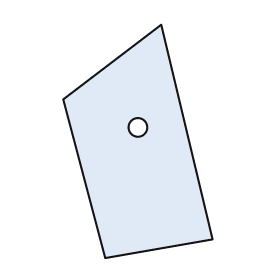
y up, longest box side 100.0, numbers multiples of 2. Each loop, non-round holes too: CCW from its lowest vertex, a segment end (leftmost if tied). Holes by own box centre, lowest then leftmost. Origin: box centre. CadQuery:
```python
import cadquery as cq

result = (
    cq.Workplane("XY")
    .moveTo(-14.0, -50.0)
    .lineTo(32.0, -42.0)
    .lineTo(10.0, 50.0)
    .lineTo(-32.0, 18.0)
    .close()
    .moveTo(0.0, 6.0)
    .circle(4.0)
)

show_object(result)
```